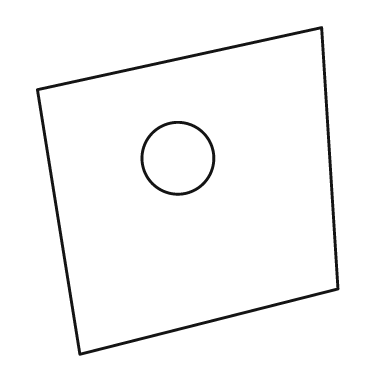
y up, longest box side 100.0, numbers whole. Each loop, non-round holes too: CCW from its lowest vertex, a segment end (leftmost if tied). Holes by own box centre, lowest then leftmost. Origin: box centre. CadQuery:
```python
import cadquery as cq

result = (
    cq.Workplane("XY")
    .moveTo(-33.0, -50.0)
    .lineTo(46.0, -30.0)
    .lineTo(41.0, 50.0)
    .lineTo(-46.0, 31.0)
    .close()
    .moveTo(-3.0, 10.0)
    .circle(11.0)
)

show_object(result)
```